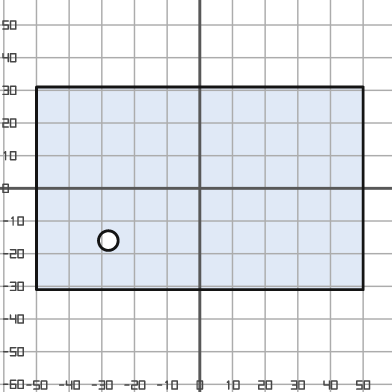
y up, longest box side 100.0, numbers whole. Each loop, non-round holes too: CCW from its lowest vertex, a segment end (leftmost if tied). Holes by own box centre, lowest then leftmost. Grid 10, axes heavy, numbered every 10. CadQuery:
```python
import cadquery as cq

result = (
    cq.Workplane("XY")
    .moveTo(-50.0, -31.0)
    .lineTo(50.0, -31.0)
    .lineTo(50.0, 31.0)
    .lineTo(-50.0, 31.0)
    .close()
    .moveTo(-28.0, -16.0)
    .circle(3.0)
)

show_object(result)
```